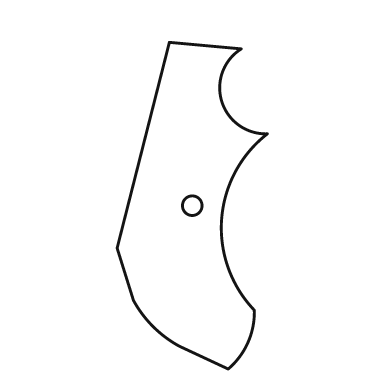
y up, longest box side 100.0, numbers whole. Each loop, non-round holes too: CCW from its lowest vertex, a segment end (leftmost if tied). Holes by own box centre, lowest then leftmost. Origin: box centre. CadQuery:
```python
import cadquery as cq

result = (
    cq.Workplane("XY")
    .moveTo(11.0, -50.0)
    .threePointArc((17.0, -42.0), (19.0, -32.0))
    .threePointArc((9.0, -4.0), (23.0, 22.0))
    .threePointArc((9.0, 32.0), (15.0, 48.0))
    .lineTo(-7.0, 50.0)
    .lineTo(-23.0, -13.0)
    .lineTo(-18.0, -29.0)
    .threePointArc((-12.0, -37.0), (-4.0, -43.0))
    .close()
    .moveTo(0.0, 0.0)
    .circle(3.0)
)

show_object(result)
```